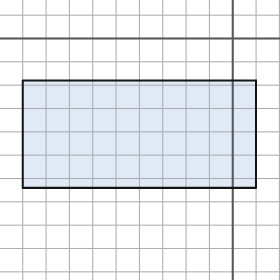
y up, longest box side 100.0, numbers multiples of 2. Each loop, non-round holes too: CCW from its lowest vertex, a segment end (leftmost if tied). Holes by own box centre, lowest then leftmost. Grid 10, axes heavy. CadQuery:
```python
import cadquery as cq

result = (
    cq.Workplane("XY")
    .moveTo(-90.0, -64.0)
    .lineTo(10.0, -64.0)
    .lineTo(10.0, -18.0)
    .lineTo(-90.0, -18.0)
    .close()
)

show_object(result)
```